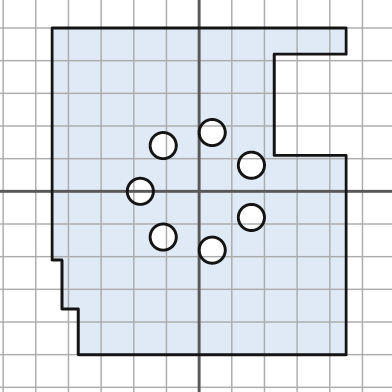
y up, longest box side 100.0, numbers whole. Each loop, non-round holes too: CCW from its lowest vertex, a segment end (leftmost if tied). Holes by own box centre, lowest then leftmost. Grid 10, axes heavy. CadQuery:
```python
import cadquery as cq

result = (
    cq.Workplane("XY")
    .moveTo(-37.0, -50.0)
    .lineTo(45.0, -50.0)
    .lineTo(45.0, 11.0)
    .lineTo(23.0, 11.0)
    .lineTo(23.0, 42.0)
    .lineTo(45.0, 42.0)
    .lineTo(45.0, 50.0)
    .lineTo(-45.0, 50.0)
    .lineTo(-45.0, -21.0)
    .lineTo(-42.0, -21.0)
    .lineTo(-42.0, -36.0)
    .lineTo(-37.0, -36.0)
    .close()
    .moveTo(4.0, -18.0)
    .circle(4.0)
    .moveTo(-11.0, -14.0)
    .circle(4.0)
    .moveTo(16.0, -8.0)
    .circle(4.0)
    .moveTo(-18.0, 0.0)
    .circle(4.0)
    .moveTo(16.0, 8.0)
    .circle(4.0)
    .moveTo(-11.0, 14.0)
    .circle(4.0)
    .moveTo(4.0, 18.0)
    .circle(4.0)
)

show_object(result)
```